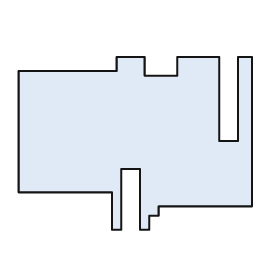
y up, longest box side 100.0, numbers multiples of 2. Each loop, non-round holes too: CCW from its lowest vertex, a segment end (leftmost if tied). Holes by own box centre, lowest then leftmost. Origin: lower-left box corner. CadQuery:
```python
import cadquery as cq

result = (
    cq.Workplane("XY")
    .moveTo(40.0, 0.0)
    .lineTo(44.0, 0.0)
    .lineTo(44.0, 26.0)
    .lineTo(52.0, 26.0)
    .lineTo(52.0, 0.0)
    .lineTo(56.0, 0.0)
    .lineTo(56.0, 6.0)
    .lineTo(60.0, 6.0)
    .lineTo(60.0, 10.0)
    .lineTo(100.0, 10.0)
    .lineTo(100.0, 74.0)
    .lineTo(94.0, 74.0)
    .lineTo(94.0, 38.0)
    .lineTo(86.0, 38.0)
    .lineTo(86.0, 74.0)
    .lineTo(68.0, 74.0)
    .lineTo(68.0, 66.0)
    .lineTo(54.0, 66.0)
    .lineTo(54.0, 74.0)
    .lineTo(42.0, 74.0)
    .lineTo(42.0, 68.0)
    .lineTo(0.0, 68.0)
    .lineTo(0.0, 16.0)
    .lineTo(40.0, 16.0)
    .close()
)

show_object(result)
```